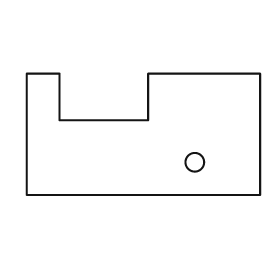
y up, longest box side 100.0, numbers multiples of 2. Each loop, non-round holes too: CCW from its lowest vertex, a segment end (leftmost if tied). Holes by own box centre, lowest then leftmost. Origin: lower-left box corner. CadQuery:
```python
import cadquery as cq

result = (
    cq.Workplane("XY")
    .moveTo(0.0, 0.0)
    .lineTo(100.0, 0.0)
    .lineTo(100.0, 52.0)
    .lineTo(52.0, 52.0)
    .lineTo(52.0, 32.0)
    .lineTo(14.0, 32.0)
    .lineTo(14.0, 52.0)
    .lineTo(0.0, 52.0)
    .close()
    .moveTo(72.0, 14.0)
    .circle(4.0)
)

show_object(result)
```